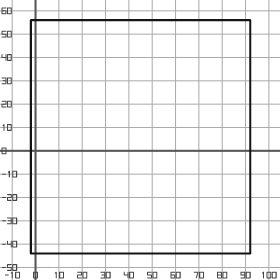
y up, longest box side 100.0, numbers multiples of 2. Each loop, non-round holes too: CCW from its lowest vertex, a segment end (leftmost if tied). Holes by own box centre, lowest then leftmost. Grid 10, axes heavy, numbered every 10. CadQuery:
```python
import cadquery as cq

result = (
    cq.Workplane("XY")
    .moveTo(-2.0, -44.0)
    .lineTo(92.0, -44.0)
    .lineTo(92.0, 56.0)
    .lineTo(-2.0, 56.0)
    .close()
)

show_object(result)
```